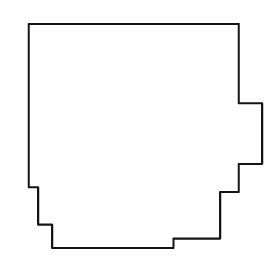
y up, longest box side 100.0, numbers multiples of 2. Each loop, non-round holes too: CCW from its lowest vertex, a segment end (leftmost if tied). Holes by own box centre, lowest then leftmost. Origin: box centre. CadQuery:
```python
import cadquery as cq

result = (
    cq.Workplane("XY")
    .moveTo(-40.0, -48.0)
    .lineTo(12.0, -48.0)
    .lineTo(12.0, -44.0)
    .lineTo(32.0, -44.0)
    .lineTo(32.0, -24.0)
    .lineTo(40.0, -24.0)
    .lineTo(40.0, -12.0)
    .lineTo(50.0, -12.0)
    .lineTo(50.0, 14.0)
    .lineTo(40.0, 14.0)
    .lineTo(40.0, 48.0)
    .lineTo(-50.0, 48.0)
    .lineTo(-50.0, -22.0)
    .lineTo(-46.0, -22.0)
    .lineTo(-46.0, -38.0)
    .lineTo(-40.0, -38.0)
    .close()
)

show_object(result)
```